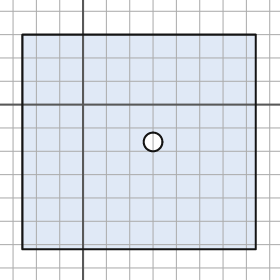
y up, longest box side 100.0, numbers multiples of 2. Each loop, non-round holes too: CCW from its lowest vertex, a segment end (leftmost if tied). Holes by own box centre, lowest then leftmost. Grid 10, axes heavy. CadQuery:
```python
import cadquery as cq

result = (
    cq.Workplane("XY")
    .moveTo(-26.0, -62.0)
    .lineTo(74.0, -62.0)
    .lineTo(74.0, 30.0)
    .lineTo(-26.0, 30.0)
    .close()
    .moveTo(30.0, -16.0)
    .circle(4.0)
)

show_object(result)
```